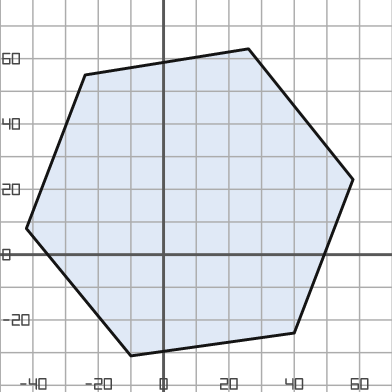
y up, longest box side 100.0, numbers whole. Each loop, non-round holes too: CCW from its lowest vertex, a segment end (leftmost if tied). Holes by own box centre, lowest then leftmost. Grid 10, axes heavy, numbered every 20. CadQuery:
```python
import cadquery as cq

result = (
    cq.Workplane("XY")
    .moveTo(-10.0, -31.0)
    .lineTo(40.0, -24.0)
    .lineTo(58.0, 23.0)
    .lineTo(26.0, 63.0)
    .lineTo(-24.0, 55.0)
    .lineTo(-42.0, 8.0)
    .close()
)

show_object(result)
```